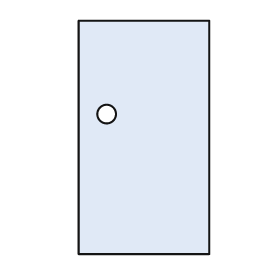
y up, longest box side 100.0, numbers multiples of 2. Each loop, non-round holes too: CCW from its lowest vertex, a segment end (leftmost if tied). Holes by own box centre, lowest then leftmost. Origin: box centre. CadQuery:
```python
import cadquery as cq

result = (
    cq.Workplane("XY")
    .moveTo(-28.0, -50.0)
    .lineTo(28.0, -50.0)
    .lineTo(28.0, 50.0)
    .lineTo(-28.0, 50.0)
    .close()
    .moveTo(-16.0, 10.0)
    .circle(4.0)
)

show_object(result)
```